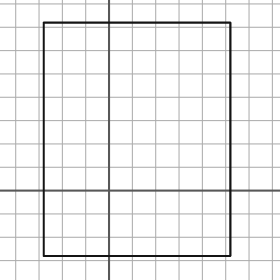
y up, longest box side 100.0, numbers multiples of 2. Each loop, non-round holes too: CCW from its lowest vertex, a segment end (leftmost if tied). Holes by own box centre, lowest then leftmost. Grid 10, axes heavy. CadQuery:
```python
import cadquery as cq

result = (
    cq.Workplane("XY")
    .moveTo(-28.0, -28.0)
    .lineTo(52.0, -28.0)
    .lineTo(52.0, 72.0)
    .lineTo(-28.0, 72.0)
    .close()
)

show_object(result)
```